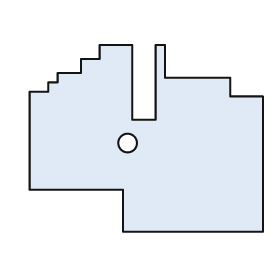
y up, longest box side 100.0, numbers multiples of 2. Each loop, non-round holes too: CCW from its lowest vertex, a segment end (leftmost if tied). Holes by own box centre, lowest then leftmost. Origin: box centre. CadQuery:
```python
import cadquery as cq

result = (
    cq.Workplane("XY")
    .moveTo(-10.0, -40.0)
    .lineTo(50.0, -40.0)
    .lineTo(50.0, 18.0)
    .lineTo(36.0, 18.0)
    .lineTo(36.0, 26.0)
    .lineTo(8.0, 26.0)
    .lineTo(8.0, 40.0)
    .lineTo(4.0, 40.0)
    .lineTo(4.0, 8.0)
    .lineTo(-6.0, 8.0)
    .lineTo(-6.0, 40.0)
    .lineTo(-20.0, 40.0)
    .lineTo(-20.0, 34.0)
    .lineTo(-28.0, 34.0)
    .lineTo(-28.0, 28.0)
    .lineTo(-38.0, 28.0)
    .lineTo(-38.0, 24.0)
    .lineTo(-42.0, 24.0)
    .lineTo(-42.0, 20.0)
    .lineTo(-50.0, 20.0)
    .lineTo(-50.0, -22.0)
    .lineTo(-10.0, -22.0)
    .close()
    .moveTo(-8.0, -2.0)
    .circle(4.0)
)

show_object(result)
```